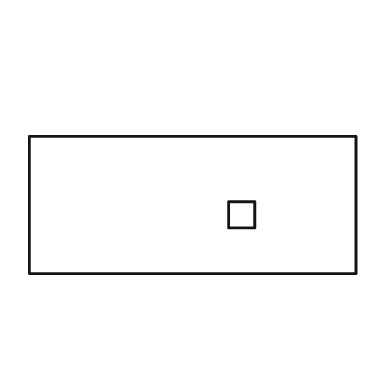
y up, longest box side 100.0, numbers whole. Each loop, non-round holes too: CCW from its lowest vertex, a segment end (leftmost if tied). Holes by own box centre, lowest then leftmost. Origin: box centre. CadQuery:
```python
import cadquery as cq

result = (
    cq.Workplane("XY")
    .moveTo(-50.0, -21.0)
    .lineTo(50.0, -21.0)
    .lineTo(50.0, 21.0)
    .lineTo(-50.0, 21.0)
    .close()
    .moveTo(11.0, -7.0)
    .lineTo(19.0, -7.0)
    .lineTo(19.0, 1.0)
    .lineTo(11.0, 1.0)
    .close()
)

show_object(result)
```